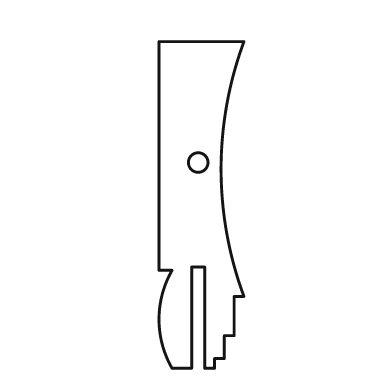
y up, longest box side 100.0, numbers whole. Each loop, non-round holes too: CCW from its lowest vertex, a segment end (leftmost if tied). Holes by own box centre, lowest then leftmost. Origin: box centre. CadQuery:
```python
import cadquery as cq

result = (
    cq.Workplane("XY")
    .moveTo(-9.0, -50.0)
    .lineTo(-3.0, -50.0)
    .lineTo(-3.0, -19.0)
    .lineTo(1.0, -19.0)
    .lineTo(1.0, -50.0)
    .lineTo(4.0, -50.0)
    .lineTo(4.0, -47.0)
    .lineTo(7.0, -47.0)
    .lineTo(7.0, -40.0)
    .lineTo(10.0, -40.0)
    .lineTo(10.0, -28.0)
    .lineTo(13.0, -28.0)
    .threePointArc((6.0, 11.0), (13.0, 50.0))
    .lineTo(-13.0, 50.0)
    .lineTo(-13.0, -20.0)
    .lineTo(-9.0, -20.0)
    .threePointArc((-13.0, -35.0), (-9.0, -50.0))
    .close()
    .moveTo(-1.0, 13.0)
    .circle(3.0)
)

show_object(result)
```